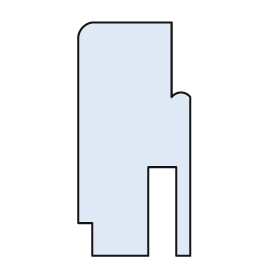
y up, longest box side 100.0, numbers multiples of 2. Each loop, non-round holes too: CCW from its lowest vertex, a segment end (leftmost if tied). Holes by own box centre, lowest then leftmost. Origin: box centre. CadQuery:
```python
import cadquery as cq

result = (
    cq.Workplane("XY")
    .moveTo(-18.0, -50.0)
    .lineTo(6.0, -50.0)
    .lineTo(6.0, -12.0)
    .lineTo(18.0, -12.0)
    .lineTo(18.0, -50.0)
    .lineTo(24.0, -50.0)
    .lineTo(24.0, 18.0)
    .threePointArc((20.0, 20.0), (16.0, 18.0))
    .lineTo(16.0, 50.0)
    .lineTo(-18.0, 50.0)
    .threePointArc((-22.0, 48.0), (-24.0, 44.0))
    .lineTo(-24.0, -36.0)
    .lineTo(-18.0, -36.0)
    .close()
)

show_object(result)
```